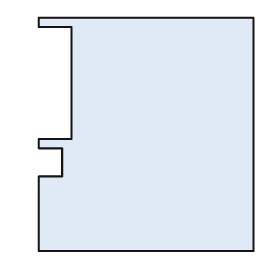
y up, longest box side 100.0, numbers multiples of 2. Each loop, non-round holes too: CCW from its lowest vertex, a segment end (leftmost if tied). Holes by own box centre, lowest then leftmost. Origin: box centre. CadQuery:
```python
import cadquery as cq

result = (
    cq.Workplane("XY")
    .moveTo(-46.0, -50.0)
    .lineTo(46.0, -50.0)
    .lineTo(46.0, 50.0)
    .lineTo(-46.0, 50.0)
    .lineTo(-46.0, 46.0)
    .lineTo(-32.0, 46.0)
    .lineTo(-32.0, -2.0)
    .lineTo(-46.0, -2.0)
    .lineTo(-46.0, -6.0)
    .lineTo(-36.0, -6.0)
    .lineTo(-36.0, -18.0)
    .lineTo(-46.0, -18.0)
    .close()
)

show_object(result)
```